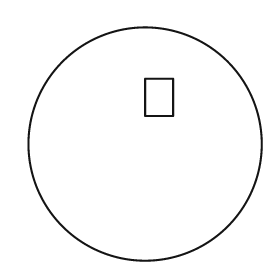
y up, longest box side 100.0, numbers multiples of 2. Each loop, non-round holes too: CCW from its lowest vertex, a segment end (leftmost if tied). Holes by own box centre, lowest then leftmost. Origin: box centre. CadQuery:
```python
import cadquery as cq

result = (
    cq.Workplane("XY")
    .moveTo(0.0, 0.0)
    .circle(50.0)
    .moveTo(0.0, 12.0)
    .lineTo(12.0, 12.0)
    .lineTo(12.0, 28.0)
    .lineTo(0.0, 28.0)
    .close()
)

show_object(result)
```